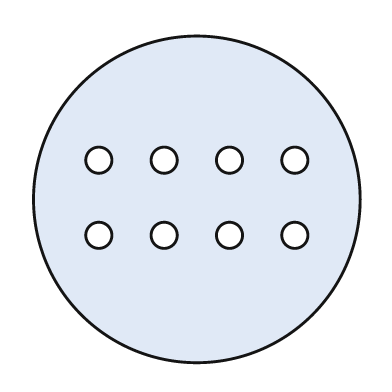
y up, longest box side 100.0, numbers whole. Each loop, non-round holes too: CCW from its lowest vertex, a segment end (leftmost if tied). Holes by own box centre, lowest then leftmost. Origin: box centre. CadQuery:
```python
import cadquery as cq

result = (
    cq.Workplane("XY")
    .moveTo(0.0, 0.0)
    .circle(50.0)
    .moveTo(-30.0, -11.0)
    .circle(4.0)
    .moveTo(-10.0, -11.0)
    .circle(4.0)
    .moveTo(10.0, -11.0)
    .circle(4.0)
    .moveTo(30.0, -11.0)
    .circle(4.0)
    .moveTo(-30.0, 12.0)
    .circle(4.0)
    .moveTo(-10.0, 12.0)
    .circle(4.0)
    .moveTo(10.0, 12.0)
    .circle(4.0)
    .moveTo(30.0, 12.0)
    .circle(4.0)
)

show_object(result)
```